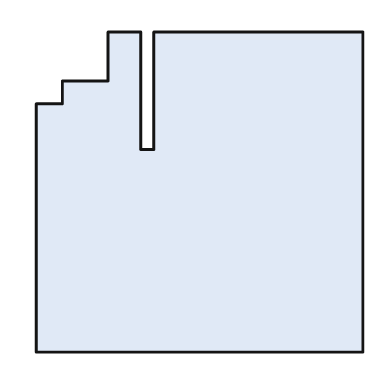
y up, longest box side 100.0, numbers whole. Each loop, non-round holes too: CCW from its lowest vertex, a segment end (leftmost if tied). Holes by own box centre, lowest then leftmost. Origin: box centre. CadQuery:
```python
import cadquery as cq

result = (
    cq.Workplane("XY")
    .moveTo(-50.0, -49.0)
    .lineTo(50.0, -49.0)
    .lineTo(50.0, 49.0)
    .lineTo(-14.0, 49.0)
    .lineTo(-14.0, 13.0)
    .lineTo(-18.0, 13.0)
    .lineTo(-18.0, 49.0)
    .lineTo(-28.0, 49.0)
    .lineTo(-28.0, 34.0)
    .lineTo(-42.0, 34.0)
    .lineTo(-42.0, 27.0)
    .lineTo(-50.0, 27.0)
    .close()
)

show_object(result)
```